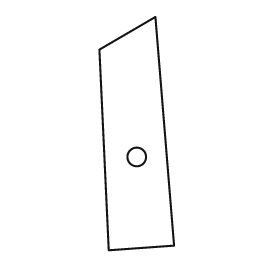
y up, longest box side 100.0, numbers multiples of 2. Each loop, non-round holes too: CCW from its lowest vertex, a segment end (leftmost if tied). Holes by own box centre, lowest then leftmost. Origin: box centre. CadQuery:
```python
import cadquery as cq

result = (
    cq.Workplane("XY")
    .moveTo(-12.0, -50.0)
    .lineTo(16.0, -48.0)
    .lineTo(8.0, 50.0)
    .lineTo(-16.0, 36.0)
    .close()
    .moveTo(0.0, -10.0)
    .circle(4.0)
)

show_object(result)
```